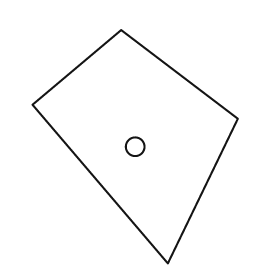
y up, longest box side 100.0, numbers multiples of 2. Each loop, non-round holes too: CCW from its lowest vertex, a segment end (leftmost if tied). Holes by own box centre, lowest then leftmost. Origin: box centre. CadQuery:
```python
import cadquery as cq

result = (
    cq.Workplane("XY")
    .moveTo(14.0, -50.0)
    .lineTo(44.0, 12.0)
    .lineTo(-6.0, 50.0)
    .lineTo(-44.0, 18.0)
    .close()
    .moveTo(0.0, 0.0)
    .circle(4.0)
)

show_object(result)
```